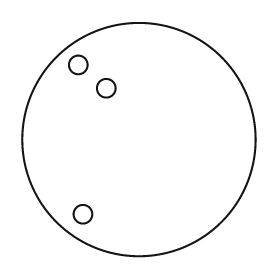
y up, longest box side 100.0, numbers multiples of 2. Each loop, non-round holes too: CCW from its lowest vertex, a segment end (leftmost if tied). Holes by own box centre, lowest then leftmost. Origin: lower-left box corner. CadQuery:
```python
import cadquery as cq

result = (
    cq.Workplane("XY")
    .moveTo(50.0, 50.0)
    .circle(50.0)
    .moveTo(26.0, 18.0)
    .circle(4.0)
    .moveTo(36.0, 72.0)
    .circle(4.0)
    .moveTo(24.0, 82.0)
    .circle(4.0)
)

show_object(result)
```